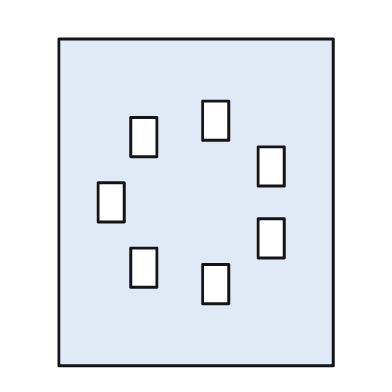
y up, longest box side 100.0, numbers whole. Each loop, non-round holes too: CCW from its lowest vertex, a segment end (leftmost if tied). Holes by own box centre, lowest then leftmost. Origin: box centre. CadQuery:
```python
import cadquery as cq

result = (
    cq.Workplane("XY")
    .moveTo(-42.0, -50.0)
    .lineTo(42.0, -50.0)
    .lineTo(42.0, 50.0)
    .lineTo(-42.0, 50.0)
    .close()
    .moveTo(2.0, -31.0)
    .lineTo(10.0, -31.0)
    .lineTo(10.0, -19.0)
    .lineTo(2.0, -19.0)
    .close()
    .moveTo(-20.0, -26.0)
    .lineTo(-12.0, -26.0)
    .lineTo(-12.0, -14.0)
    .lineTo(-20.0, -14.0)
    .close()
    .moveTo(19.0, -17.0)
    .lineTo(27.0, -17.0)
    .lineTo(27.0, -5.0)
    .lineTo(19.0, -5.0)
    .close()
    .moveTo(-30.0, -6.0)
    .lineTo(-22.0, -6.0)
    .lineTo(-22.0, 6.0)
    .lineTo(-30.0, 6.0)
    .close()
    .moveTo(19.0, 5.0)
    .lineTo(27.0, 5.0)
    .lineTo(27.0, 17.0)
    .lineTo(19.0, 17.0)
    .close()
    .moveTo(-20.0, 14.0)
    .lineTo(-12.0, 14.0)
    .lineTo(-12.0, 26.0)
    .lineTo(-20.0, 26.0)
    .close()
    .moveTo(2.0, 19.0)
    .lineTo(10.0, 19.0)
    .lineTo(10.0, 31.0)
    .lineTo(2.0, 31.0)
    .close()
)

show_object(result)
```